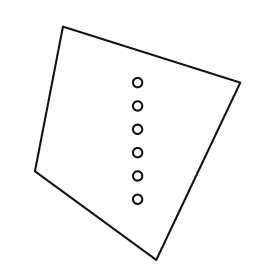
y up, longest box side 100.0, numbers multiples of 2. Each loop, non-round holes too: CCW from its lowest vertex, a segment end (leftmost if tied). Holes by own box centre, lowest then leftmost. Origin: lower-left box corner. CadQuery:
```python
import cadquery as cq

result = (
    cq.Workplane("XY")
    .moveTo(52.0, 0.0)
    .lineTo(88.0, 76.0)
    .lineTo(12.0, 100.0)
    .lineTo(0.0, 38.0)
    .close()
    .moveTo(44.0, 26.0)
    .circle(2.0)
    .moveTo(44.0, 36.0)
    .circle(2.0)
    .moveTo(44.0, 46.0)
    .circle(2.0)
    .moveTo(44.0, 56.0)
    .circle(2.0)
    .moveTo(44.0, 66.0)
    .circle(2.0)
    .moveTo(44.0, 76.0)
    .circle(2.0)
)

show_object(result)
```